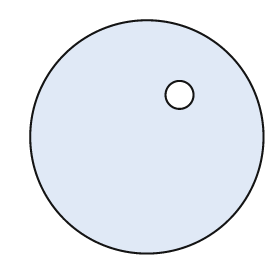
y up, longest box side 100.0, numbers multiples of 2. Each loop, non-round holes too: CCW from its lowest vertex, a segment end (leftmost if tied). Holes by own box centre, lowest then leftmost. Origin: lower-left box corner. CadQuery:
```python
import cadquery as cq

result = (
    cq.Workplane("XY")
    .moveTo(50.0, 50.0)
    .circle(50.0)
    .moveTo(64.0, 68.0)
    .circle(6.0)
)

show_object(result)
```